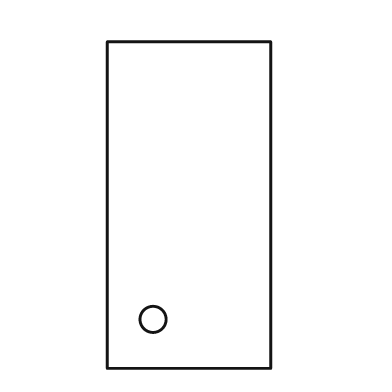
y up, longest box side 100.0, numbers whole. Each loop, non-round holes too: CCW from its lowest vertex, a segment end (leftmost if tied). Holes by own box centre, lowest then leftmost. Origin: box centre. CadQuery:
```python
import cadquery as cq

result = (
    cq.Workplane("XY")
    .moveTo(-25.0, -50.0)
    .lineTo(25.0, -50.0)
    .lineTo(25.0, 50.0)
    .lineTo(-25.0, 50.0)
    .close()
    .moveTo(-11.0, -35.0)
    .circle(4.0)
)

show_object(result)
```